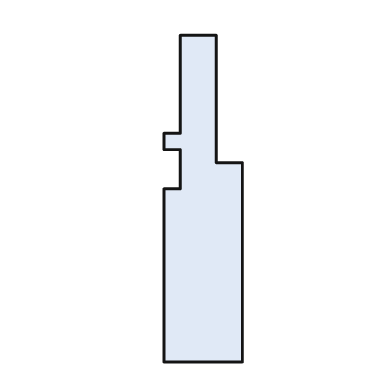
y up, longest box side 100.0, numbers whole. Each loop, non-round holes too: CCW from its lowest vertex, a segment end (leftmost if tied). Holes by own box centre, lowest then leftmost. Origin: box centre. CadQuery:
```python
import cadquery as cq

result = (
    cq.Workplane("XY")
    .moveTo(-12.0, -50.0)
    .lineTo(12.0, -50.0)
    .lineTo(12.0, 11.0)
    .lineTo(4.0, 11.0)
    .lineTo(4.0, 50.0)
    .lineTo(-7.0, 50.0)
    .lineTo(-7.0, 20.0)
    .lineTo(-12.0, 20.0)
    .lineTo(-12.0, 15.0)
    .lineTo(-7.0, 15.0)
    .lineTo(-7.0, 3.0)
    .lineTo(-12.0, 3.0)
    .close()
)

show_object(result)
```